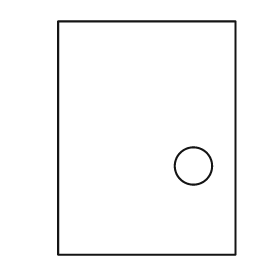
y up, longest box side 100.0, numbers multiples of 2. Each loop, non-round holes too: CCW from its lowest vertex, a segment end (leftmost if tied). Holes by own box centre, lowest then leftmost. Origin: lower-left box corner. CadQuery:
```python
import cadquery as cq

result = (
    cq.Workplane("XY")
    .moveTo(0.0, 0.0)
    .lineTo(76.0, 0.0)
    .lineTo(76.0, 100.0)
    .lineTo(0.0, 100.0)
    .close()
    .moveTo(58.0, 38.0)
    .circle(8.0)
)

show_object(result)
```